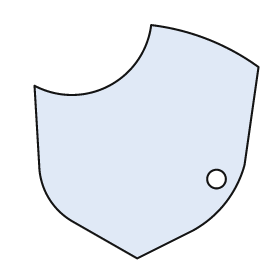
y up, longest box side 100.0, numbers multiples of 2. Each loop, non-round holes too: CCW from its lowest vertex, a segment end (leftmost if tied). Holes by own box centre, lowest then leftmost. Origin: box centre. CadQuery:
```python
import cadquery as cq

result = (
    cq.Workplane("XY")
    .moveTo(-4.0, -50.0)
    .lineTo(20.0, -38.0)
    .threePointArc((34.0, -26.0), (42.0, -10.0))
    .lineTo(48.0, 32.0)
    .threePointArc((26.0, 44.0), (2.0, 50.0))
    .threePointArc((-16.0, 24.0), (-48.0, 24.0))
    .lineTo(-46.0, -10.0)
    .threePointArc((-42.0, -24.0), (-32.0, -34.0))
    .close()
    .moveTo(30.0, -16.0)
    .circle(4.0)
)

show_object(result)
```